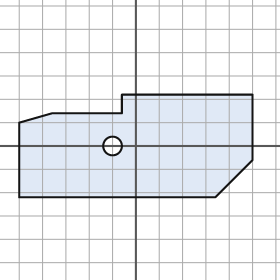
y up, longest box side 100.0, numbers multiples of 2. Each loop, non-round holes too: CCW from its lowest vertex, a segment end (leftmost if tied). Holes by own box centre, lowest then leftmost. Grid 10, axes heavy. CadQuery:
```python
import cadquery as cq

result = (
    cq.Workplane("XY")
    .moveTo(-50.0, -22.0)
    .lineTo(34.0, -22.0)
    .lineTo(50.0, -6.0)
    .lineTo(50.0, 22.0)
    .lineTo(-6.0, 22.0)
    .lineTo(-6.0, 14.0)
    .lineTo(-36.0, 14.0)
    .lineTo(-50.0, 10.0)
    .close()
    .moveTo(-10.0, 0.0)
    .circle(4.0)
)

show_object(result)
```